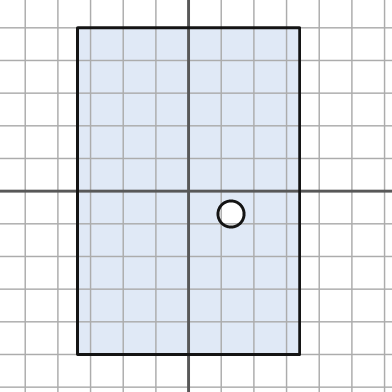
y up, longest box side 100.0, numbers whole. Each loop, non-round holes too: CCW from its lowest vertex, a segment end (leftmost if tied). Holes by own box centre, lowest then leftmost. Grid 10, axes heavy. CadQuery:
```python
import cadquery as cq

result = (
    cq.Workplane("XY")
    .moveTo(-34.0, -50.0)
    .lineTo(34.0, -50.0)
    .lineTo(34.0, 50.0)
    .lineTo(-34.0, 50.0)
    .close()
    .moveTo(13.0, -7.0)
    .circle(4.0)
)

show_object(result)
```